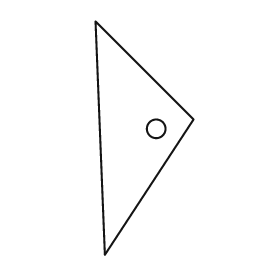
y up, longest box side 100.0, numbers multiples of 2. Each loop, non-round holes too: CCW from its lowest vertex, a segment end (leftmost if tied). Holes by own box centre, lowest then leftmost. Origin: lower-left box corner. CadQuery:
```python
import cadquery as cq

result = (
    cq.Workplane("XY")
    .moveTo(4.0, 0.0)
    .lineTo(42.0, 58.0)
    .lineTo(0.0, 100.0)
    .close()
    .moveTo(26.0, 54.0)
    .circle(4.0)
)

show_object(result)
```